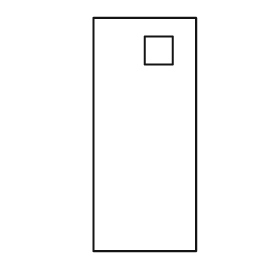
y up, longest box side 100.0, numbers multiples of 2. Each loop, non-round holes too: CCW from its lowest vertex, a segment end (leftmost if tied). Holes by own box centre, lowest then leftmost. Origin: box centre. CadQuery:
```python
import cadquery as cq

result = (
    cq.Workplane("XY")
    .moveTo(-22.0, -50.0)
    .lineTo(22.0, -50.0)
    .lineTo(22.0, 50.0)
    .lineTo(-22.0, 50.0)
    .close()
    .moveTo(0.0, 30.0)
    .lineTo(12.0, 30.0)
    .lineTo(12.0, 42.0)
    .lineTo(0.0, 42.0)
    .close()
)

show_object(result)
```